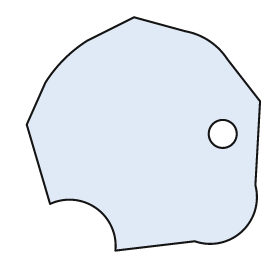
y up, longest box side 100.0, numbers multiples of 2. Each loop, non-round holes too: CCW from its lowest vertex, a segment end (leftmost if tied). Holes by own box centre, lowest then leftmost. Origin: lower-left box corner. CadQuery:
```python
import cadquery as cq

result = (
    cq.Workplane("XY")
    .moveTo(38.0, 0.0)
    .lineTo(72.0, 4.0)
    .threePointArc((92.0, 8.0), (98.0, 28.0))
    .lineTo(100.0, 64.0)
    .lineTo(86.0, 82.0)
    .threePointArc((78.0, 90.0), (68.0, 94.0))
    .lineTo(46.0, 100.0)
    .lineTo(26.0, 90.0)
    .threePointArc((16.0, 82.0), (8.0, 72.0))
    .lineTo(0.0, 54.0)
    .lineTo(10.0, 20.0)
    .threePointArc((30.0, 18.0), (38.0, 0.0))
    .close()
    .moveTo(84.0, 50.0)
    .circle(6.0)
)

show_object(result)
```